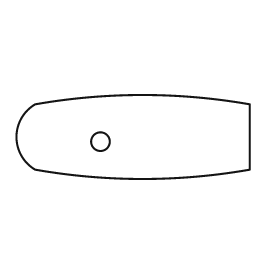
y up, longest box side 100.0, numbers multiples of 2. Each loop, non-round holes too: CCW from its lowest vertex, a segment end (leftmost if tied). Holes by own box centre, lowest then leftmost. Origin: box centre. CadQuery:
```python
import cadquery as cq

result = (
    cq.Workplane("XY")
    .moveTo(-42.0, -14.0)
    .threePointArc((4.0, -18.0), (50.0, -14.0))
    .lineTo(50.0, 14.0)
    .threePointArc((4.0, 18.0), (-42.0, 14.0))
    .threePointArc((-50.0, 0.0), (-42.0, -14.0))
    .close()
    .moveTo(-14.0, -2.0)
    .circle(4.0)
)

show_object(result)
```